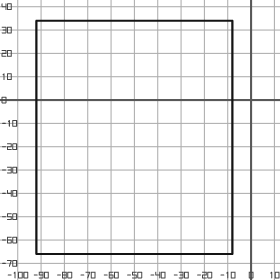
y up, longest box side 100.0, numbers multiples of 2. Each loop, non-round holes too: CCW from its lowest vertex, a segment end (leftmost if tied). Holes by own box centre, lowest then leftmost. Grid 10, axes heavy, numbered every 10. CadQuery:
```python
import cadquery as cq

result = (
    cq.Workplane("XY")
    .moveTo(-92.0, -66.0)
    .lineTo(-8.0, -66.0)
    .lineTo(-8.0, 34.0)
    .lineTo(-92.0, 34.0)
    .close()
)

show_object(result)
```